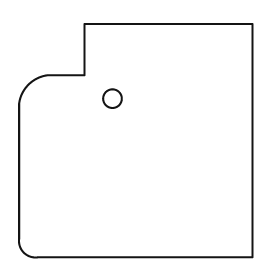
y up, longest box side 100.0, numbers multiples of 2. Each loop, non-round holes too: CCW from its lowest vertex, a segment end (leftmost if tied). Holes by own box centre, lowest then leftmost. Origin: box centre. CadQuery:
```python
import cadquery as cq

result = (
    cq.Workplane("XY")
    .moveTo(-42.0, -50.0)
    .lineTo(50.0, -50.0)
    .lineTo(50.0, 50.0)
    .lineTo(-22.0, 50.0)
    .lineTo(-22.0, 28.0)
    .lineTo(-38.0, 28.0)
    .threePointArc((-46.0, 24.0), (-50.0, 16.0))
    .lineTo(-50.0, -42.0)
    .threePointArc((-48.0, -48.0), (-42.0, -50.0))
    .close()
    .moveTo(-10.0, 18.0)
    .circle(4.0)
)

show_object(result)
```